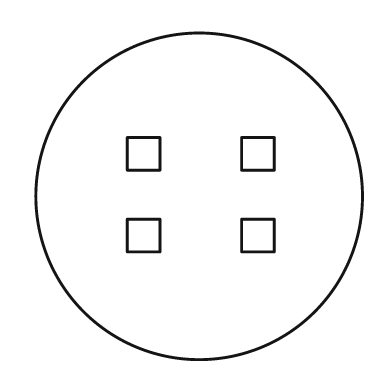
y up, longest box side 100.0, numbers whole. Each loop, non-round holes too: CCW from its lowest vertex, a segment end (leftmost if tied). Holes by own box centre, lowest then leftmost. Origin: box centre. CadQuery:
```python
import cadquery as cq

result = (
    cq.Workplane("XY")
    .moveTo(0.0, 0.0)
    .circle(50.0)
    .moveTo(-22.0, -17.0)
    .lineTo(-12.0, -17.0)
    .lineTo(-12.0, -7.0)
    .lineTo(-22.0, -7.0)
    .close()
    .moveTo(13.0, -17.0)
    .lineTo(23.0, -17.0)
    .lineTo(23.0, -7.0)
    .lineTo(13.0, -7.0)
    .close()
    .moveTo(-22.0, 8.0)
    .lineTo(-12.0, 8.0)
    .lineTo(-12.0, 18.0)
    .lineTo(-22.0, 18.0)
    .close()
    .moveTo(13.0, 8.0)
    .lineTo(23.0, 8.0)
    .lineTo(23.0, 18.0)
    .lineTo(13.0, 18.0)
    .close()
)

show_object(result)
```